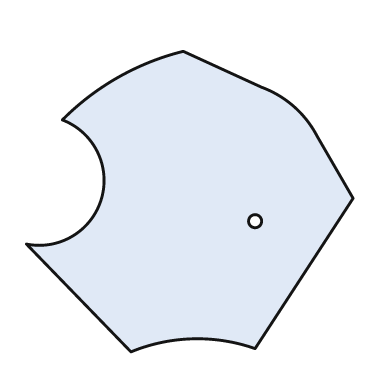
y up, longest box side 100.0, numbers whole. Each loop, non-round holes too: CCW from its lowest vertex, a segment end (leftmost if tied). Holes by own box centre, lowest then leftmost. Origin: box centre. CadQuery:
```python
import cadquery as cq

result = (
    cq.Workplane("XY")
    .moveTo(-18.0, -46.0)
    .threePointArc((1.0, -42.0), (20.0, -45.0))
    .lineTo(50.0, 1.0)
    .lineTo(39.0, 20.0)
    .threePointArc((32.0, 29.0), (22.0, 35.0))
    .lineTo(-2.0, 46.0)
    .threePointArc((-22.0, 38.0), (-39.0, 25.0))
    .threePointArc((-27.0, 1.0), (-50.0, -13.0))
    .close()
    .moveTo(20.0, -6.0)
    .circle(2.0)
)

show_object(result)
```